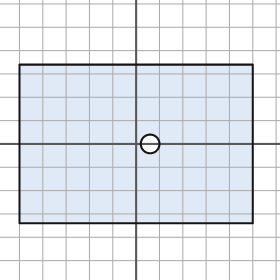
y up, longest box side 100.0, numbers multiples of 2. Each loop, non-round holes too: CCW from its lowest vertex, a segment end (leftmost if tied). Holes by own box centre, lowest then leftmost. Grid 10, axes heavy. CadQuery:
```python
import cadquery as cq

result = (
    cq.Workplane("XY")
    .moveTo(-50.0, -34.0)
    .lineTo(50.0, -34.0)
    .lineTo(50.0, 34.0)
    .lineTo(-50.0, 34.0)
    .close()
    .moveTo(6.0, 0.0)
    .circle(4.0)
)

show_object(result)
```